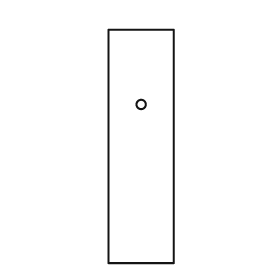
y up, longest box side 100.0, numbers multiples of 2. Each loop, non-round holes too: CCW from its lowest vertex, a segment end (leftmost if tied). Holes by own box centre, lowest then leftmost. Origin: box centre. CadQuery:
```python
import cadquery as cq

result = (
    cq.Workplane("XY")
    .moveTo(-14.0, -50.0)
    .lineTo(14.0, -50.0)
    .lineTo(14.0, 50.0)
    .lineTo(-14.0, 50.0)
    .close()
    .moveTo(0.0, 18.0)
    .circle(2.0)
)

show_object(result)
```